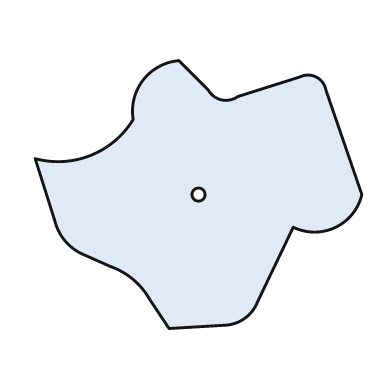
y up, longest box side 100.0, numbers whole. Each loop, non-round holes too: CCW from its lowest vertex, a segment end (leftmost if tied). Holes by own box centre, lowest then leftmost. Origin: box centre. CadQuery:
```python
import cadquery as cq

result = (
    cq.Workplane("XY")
    .moveTo(-9.0, -41.0)
    .lineTo(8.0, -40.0)
    .threePointArc((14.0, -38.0), (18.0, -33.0))
    .lineTo(29.0, -10.0)
    .threePointArc((42.0, -10.0), (50.0, 0.0))
    .lineTo(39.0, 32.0)
    .threePointArc((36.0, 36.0), (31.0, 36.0))
    .lineTo(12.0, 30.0)
    .threePointArc((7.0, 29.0), (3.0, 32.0))
    .lineTo(-6.0, 41.0)
    .threePointArc((-17.0, 35.0), (-20.0, 23.0))
    .threePointArc((-33.0, 12.0), (-50.0, 11.0))
    .lineTo(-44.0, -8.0)
    .threePointArc((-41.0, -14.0), (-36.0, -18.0))
    .lineTo(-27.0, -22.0)
    .threePointArc((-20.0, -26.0), (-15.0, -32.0))
    .close()
    .moveTo(0.0, 0.0)
    .circle(2.0)
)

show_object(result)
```